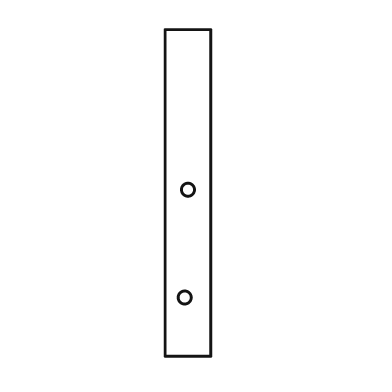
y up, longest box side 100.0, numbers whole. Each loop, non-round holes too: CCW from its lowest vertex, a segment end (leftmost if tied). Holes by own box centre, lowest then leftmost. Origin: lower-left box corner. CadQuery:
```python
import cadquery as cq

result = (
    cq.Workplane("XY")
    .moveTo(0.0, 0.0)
    .lineTo(14.0, 0.0)
    .lineTo(14.0, 100.0)
    .lineTo(0.0, 100.0)
    .close()
    .moveTo(6.0, 18.0)
    .circle(2.0)
    .moveTo(7.0, 51.0)
    .circle(2.0)
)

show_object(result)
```